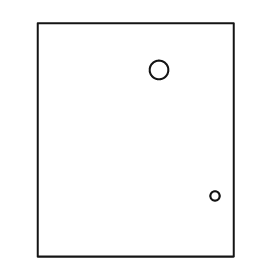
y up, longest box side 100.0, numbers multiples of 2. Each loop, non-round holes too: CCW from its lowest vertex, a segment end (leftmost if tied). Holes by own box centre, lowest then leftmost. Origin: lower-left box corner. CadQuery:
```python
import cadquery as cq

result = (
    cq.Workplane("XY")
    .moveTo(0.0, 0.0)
    .lineTo(84.0, 0.0)
    .lineTo(84.0, 100.0)
    .lineTo(0.0, 100.0)
    .close()
    .moveTo(76.0, 26.0)
    .circle(2.0)
    .moveTo(52.0, 80.0)
    .circle(4.0)
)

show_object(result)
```